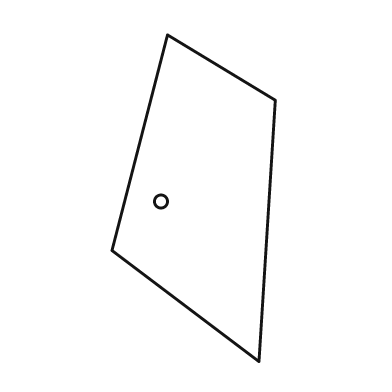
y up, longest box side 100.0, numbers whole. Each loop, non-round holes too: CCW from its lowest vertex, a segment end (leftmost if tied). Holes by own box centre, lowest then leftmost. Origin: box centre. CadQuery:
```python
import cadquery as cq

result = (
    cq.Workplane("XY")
    .moveTo(20.0, -50.0)
    .lineTo(25.0, 30.0)
    .lineTo(-8.0, 50.0)
    .lineTo(-25.0, -16.0)
    .close()
    .moveTo(-10.0, -1.0)
    .circle(2.0)
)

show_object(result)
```